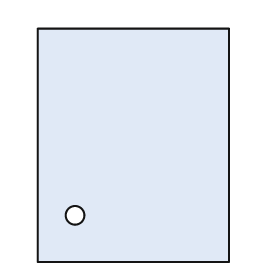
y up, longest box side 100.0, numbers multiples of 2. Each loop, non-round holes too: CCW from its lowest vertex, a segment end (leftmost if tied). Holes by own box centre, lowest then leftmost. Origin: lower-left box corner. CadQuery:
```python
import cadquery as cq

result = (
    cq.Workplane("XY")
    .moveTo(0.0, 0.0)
    .lineTo(82.0, 0.0)
    .lineTo(82.0, 100.0)
    .lineTo(0.0, 100.0)
    .close()
    .moveTo(16.0, 20.0)
    .circle(4.0)
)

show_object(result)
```